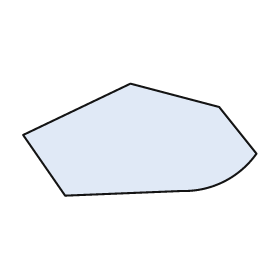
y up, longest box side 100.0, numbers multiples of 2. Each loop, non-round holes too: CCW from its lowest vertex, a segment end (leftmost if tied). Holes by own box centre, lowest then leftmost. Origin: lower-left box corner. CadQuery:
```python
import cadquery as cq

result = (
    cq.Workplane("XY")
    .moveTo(18.0, 0.0)
    .lineTo(68.0, 2.0)
    .threePointArc((86.0, 6.0), (100.0, 18.0))
    .lineTo(84.0, 38.0)
    .lineTo(46.0, 48.0)
    .lineTo(0.0, 26.0)
    .close()
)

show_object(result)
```